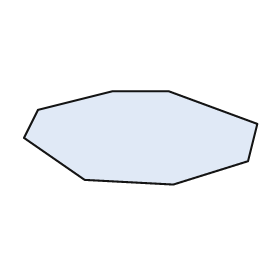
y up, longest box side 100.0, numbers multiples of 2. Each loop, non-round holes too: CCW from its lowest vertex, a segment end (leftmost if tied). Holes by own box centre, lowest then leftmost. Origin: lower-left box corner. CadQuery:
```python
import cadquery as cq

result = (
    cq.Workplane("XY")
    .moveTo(64.0, 0.0)
    .lineTo(96.0, 10.0)
    .lineTo(100.0, 26.0)
    .lineTo(62.0, 40.0)
    .lineTo(38.0, 40.0)
    .lineTo(6.0, 32.0)
    .lineTo(0.0, 20.0)
    .lineTo(26.0, 2.0)
    .close()
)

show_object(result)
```